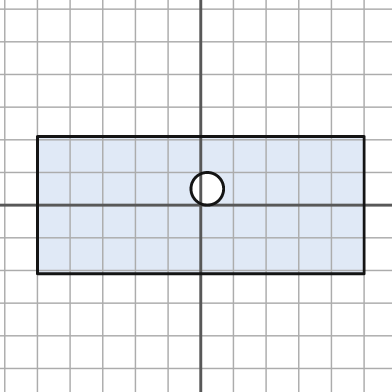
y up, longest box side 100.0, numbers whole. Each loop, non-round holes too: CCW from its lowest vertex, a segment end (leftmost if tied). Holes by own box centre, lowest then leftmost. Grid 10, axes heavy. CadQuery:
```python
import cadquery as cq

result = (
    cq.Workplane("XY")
    .moveTo(-50.0, -21.0)
    .lineTo(50.0, -21.0)
    .lineTo(50.0, 21.0)
    .lineTo(-50.0, 21.0)
    .close()
    .moveTo(2.0, 5.0)
    .circle(5.0)
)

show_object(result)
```